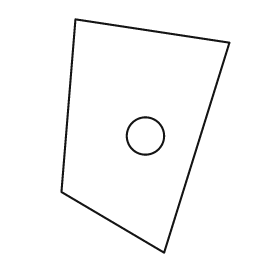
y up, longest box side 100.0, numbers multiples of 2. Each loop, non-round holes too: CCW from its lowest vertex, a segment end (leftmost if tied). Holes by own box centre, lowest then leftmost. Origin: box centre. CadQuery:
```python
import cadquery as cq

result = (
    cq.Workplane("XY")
    .moveTo(8.0, -50.0)
    .lineTo(36.0, 40.0)
    .lineTo(-30.0, 50.0)
    .lineTo(-36.0, -24.0)
    .close()
    .moveTo(0.0, 0.0)
    .circle(8.0)
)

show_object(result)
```